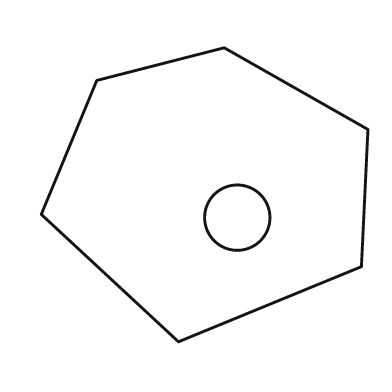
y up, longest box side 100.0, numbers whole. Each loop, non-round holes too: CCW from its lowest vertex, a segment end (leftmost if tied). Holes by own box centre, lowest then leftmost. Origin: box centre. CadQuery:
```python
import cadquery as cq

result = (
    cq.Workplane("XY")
    .moveTo(-8.0, -45.0)
    .lineTo(48.0, -22.0)
    .lineTo(50.0, 20.0)
    .lineTo(6.0, 45.0)
    .lineTo(-33.0, 35.0)
    .lineTo(-50.0, -6.0)
    .close()
    .moveTo(10.0, -7.0)
    .circle(10.0)
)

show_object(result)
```